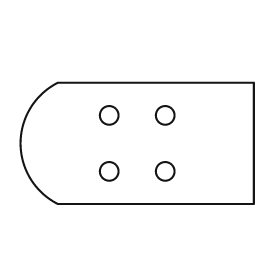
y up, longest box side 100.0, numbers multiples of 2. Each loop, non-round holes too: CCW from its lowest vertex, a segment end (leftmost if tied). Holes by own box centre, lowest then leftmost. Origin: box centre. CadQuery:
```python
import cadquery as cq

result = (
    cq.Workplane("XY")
    .moveTo(-34.0, -26.0)
    .lineTo(50.0, -26.0)
    .lineTo(50.0, 26.0)
    .lineTo(-34.0, 26.0)
    .threePointArc((-50.0, 0.0), (-34.0, -26.0))
    .close()
    .moveTo(-12.0, -12.0)
    .circle(4.0)
    .moveTo(12.0, -12.0)
    .circle(4.0)
    .moveTo(-12.0, 12.0)
    .circle(4.0)
    .moveTo(12.0, 12.0)
    .circle(4.0)
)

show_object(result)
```